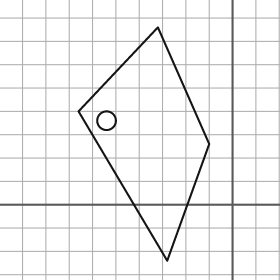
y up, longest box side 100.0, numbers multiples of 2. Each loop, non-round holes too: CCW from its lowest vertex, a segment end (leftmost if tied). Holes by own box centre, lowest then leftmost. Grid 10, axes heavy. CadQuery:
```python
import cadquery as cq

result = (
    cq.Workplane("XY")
    .moveTo(-28.0, -24.0)
    .lineTo(-10.0, 26.0)
    .lineTo(-32.0, 76.0)
    .lineTo(-66.0, 40.0)
    .close()
    .moveTo(-54.0, 36.0)
    .circle(4.0)
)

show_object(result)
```